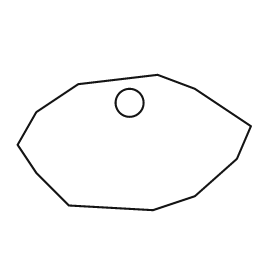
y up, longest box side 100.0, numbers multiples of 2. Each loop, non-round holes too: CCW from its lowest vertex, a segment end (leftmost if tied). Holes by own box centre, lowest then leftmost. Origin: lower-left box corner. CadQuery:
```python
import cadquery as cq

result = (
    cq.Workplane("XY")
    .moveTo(58.0, 0.0)
    .lineTo(76.0, 6.0)
    .lineTo(94.0, 22.0)
    .lineTo(100.0, 36.0)
    .lineTo(76.0, 52.0)
    .lineTo(60.0, 58.0)
    .lineTo(26.0, 54.0)
    .lineTo(8.0, 42.0)
    .lineTo(0.0, 28.0)
    .lineTo(8.0, 16.0)
    .lineTo(22.0, 2.0)
    .close()
    .moveTo(48.0, 46.0)
    .circle(6.0)
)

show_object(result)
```